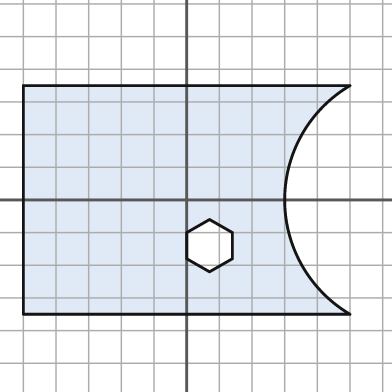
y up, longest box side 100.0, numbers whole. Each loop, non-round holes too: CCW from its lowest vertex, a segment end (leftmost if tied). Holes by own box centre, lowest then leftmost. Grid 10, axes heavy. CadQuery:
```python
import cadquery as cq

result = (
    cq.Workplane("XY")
    .moveTo(-50.0, -35.0)
    .lineTo(50.0, -35.0)
    .threePointArc((30.0, 0.0), (50.0, 35.0))
    .lineTo(-50.0, 35.0)
    .close()
    .moveTo(7.0, -22.0)
    .lineTo(14.0, -18.0)
    .lineTo(14.0, -10.0)
    .lineTo(7.0, -6.0)
    .lineTo(0.0, -10.0)
    .lineTo(0.0, -18.0)
    .close()
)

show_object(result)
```